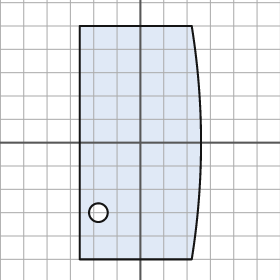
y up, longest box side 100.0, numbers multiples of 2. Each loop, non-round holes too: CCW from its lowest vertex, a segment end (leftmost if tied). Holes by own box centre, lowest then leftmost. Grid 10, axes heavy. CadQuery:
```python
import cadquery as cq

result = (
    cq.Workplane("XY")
    .moveTo(-26.0, -50.0)
    .lineTo(22.0, -50.0)
    .threePointArc((26.0, 0.0), (22.0, 50.0))
    .lineTo(-26.0, 50.0)
    .close()
    .moveTo(-18.0, -30.0)
    .circle(4.0)
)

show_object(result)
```